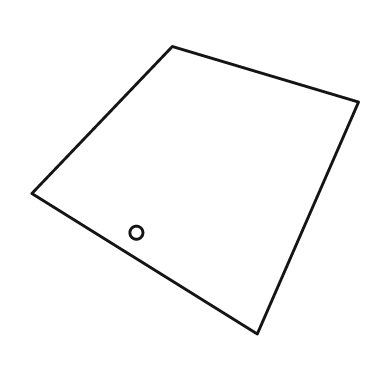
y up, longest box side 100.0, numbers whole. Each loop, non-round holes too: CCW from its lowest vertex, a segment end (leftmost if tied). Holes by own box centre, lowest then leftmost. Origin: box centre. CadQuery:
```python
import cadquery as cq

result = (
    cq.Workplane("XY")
    .moveTo(19.0, -44.0)
    .lineTo(50.0, 27.0)
    .lineTo(-7.0, 44.0)
    .lineTo(-50.0, -1.0)
    .close()
    .moveTo(-18.0, -13.0)
    .circle(2.0)
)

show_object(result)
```